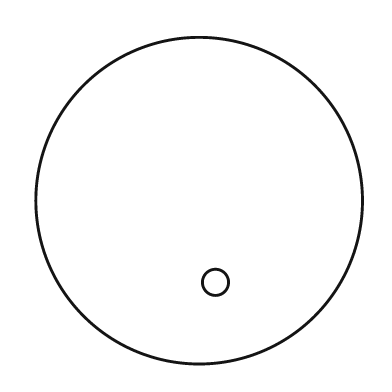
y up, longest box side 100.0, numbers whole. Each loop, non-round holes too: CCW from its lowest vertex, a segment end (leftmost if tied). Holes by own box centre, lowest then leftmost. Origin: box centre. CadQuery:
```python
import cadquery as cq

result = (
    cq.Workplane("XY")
    .moveTo(0.0, 0.0)
    .circle(50.0)
    .moveTo(5.0, -25.0)
    .circle(4.0)
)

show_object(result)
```